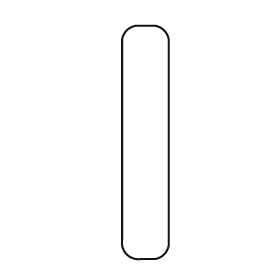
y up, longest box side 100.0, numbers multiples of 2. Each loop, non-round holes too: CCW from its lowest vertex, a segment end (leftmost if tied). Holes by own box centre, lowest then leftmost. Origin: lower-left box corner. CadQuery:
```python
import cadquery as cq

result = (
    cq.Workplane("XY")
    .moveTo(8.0, 0.0)
    .lineTo(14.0, 0.0)
    .threePointArc((18.0, 2.0), (20.0, 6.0))
    .lineTo(20.0, 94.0)
    .threePointArc((18.0, 98.0), (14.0, 100.0))
    .lineTo(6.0, 100.0)
    .threePointArc((2.0, 98.0), (0.0, 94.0))
    .lineTo(0.0, 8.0)
    .threePointArc((2.0, 2.0), (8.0, 0.0))
    .close()
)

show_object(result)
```